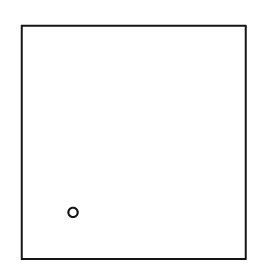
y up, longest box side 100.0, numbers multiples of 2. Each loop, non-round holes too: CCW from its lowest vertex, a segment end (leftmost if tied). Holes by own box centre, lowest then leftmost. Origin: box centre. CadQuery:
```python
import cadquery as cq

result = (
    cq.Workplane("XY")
    .moveTo(-48.0, -50.0)
    .lineTo(48.0, -50.0)
    .lineTo(48.0, 50.0)
    .lineTo(-48.0, 50.0)
    .close()
    .moveTo(-26.0, -30.0)
    .circle(2.0)
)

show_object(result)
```